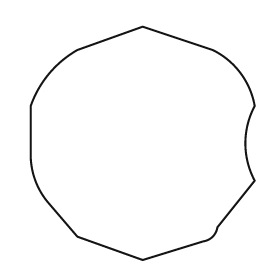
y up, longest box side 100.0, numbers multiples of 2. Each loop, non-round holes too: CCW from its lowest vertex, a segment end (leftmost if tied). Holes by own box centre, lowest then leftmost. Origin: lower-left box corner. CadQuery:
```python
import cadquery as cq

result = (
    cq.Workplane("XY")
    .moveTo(48.0, 0.0)
    .lineTo(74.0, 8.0)
    .threePointArc((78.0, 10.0), (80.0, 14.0))
    .lineTo(96.0, 34.0)
    .threePointArc((92.0, 50.0), (96.0, 66.0))
    .threePointArc((90.0, 80.0), (78.0, 90.0))
    .lineTo(48.0, 100.0)
    .lineTo(20.0, 90.0)
    .threePointArc((8.0, 80.0), (0.0, 66.0))
    .lineTo(0.0, 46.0)
    .threePointArc((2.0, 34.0), (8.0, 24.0))
    .lineTo(20.0, 10.0)
    .close()
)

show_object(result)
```